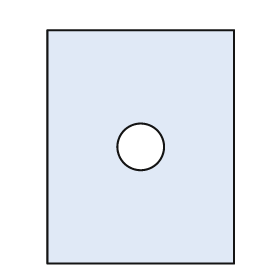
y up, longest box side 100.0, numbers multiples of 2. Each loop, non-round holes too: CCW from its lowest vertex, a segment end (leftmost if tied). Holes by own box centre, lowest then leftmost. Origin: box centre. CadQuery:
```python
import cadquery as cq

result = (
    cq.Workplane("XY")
    .moveTo(-40.0, -50.0)
    .lineTo(40.0, -50.0)
    .lineTo(40.0, 50.0)
    .lineTo(-40.0, 50.0)
    .close()
    .moveTo(0.0, 0.0)
    .circle(10.0)
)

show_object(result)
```